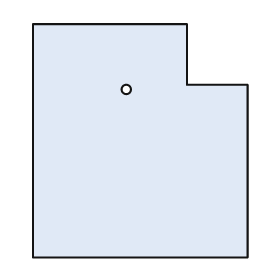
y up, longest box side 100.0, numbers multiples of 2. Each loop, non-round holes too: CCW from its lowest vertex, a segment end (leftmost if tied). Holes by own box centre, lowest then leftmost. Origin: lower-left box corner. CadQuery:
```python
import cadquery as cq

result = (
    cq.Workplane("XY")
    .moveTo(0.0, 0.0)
    .lineTo(92.0, 0.0)
    .lineTo(92.0, 74.0)
    .lineTo(66.0, 74.0)
    .lineTo(66.0, 100.0)
    .lineTo(0.0, 100.0)
    .close()
    .moveTo(40.0, 72.0)
    .circle(2.0)
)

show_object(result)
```